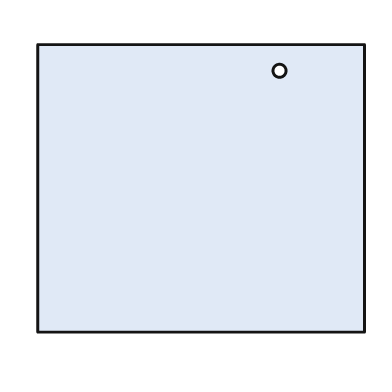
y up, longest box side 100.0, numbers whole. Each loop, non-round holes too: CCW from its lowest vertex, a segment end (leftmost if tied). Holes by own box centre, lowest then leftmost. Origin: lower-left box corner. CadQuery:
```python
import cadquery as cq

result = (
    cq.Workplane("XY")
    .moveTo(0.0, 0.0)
    .lineTo(100.0, 0.0)
    .lineTo(100.0, 88.0)
    .lineTo(0.0, 88.0)
    .close()
    .moveTo(74.0, 80.0)
    .circle(2.0)
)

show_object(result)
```